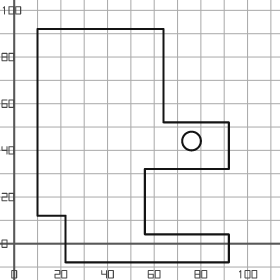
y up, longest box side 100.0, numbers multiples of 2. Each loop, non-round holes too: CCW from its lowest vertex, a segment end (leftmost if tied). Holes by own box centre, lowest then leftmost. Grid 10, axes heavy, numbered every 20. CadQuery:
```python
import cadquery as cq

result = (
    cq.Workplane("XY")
    .moveTo(22.0, -8.0)
    .lineTo(92.0, -8.0)
    .lineTo(92.0, 4.0)
    .lineTo(56.0, 4.0)
    .lineTo(56.0, 32.0)
    .lineTo(92.0, 32.0)
    .lineTo(92.0, 52.0)
    .lineTo(64.0, 52.0)
    .lineTo(64.0, 92.0)
    .lineTo(10.0, 92.0)
    .lineTo(10.0, 12.0)
    .lineTo(22.0, 12.0)
    .close()
    .moveTo(76.0, 44.0)
    .circle(4.0)
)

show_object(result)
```